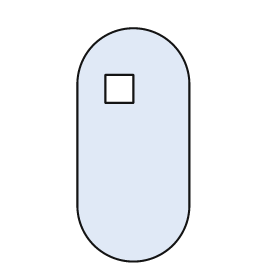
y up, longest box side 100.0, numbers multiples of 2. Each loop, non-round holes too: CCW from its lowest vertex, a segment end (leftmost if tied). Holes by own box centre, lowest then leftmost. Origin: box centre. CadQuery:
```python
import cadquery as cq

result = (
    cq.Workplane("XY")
    .moveTo(-24.0, -26.0)
    .threePointArc((0.0, -50.0), (24.0, -26.0))
    .lineTo(24.0, 26.0)
    .threePointArc((0.0, 50.0), (-24.0, 26.0))
    .close()
    .moveTo(-12.0, 18.0)
    .lineTo(0.0, 18.0)
    .lineTo(0.0, 30.0)
    .lineTo(-12.0, 30.0)
    .close()
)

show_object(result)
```